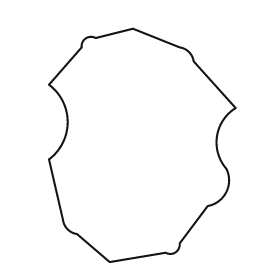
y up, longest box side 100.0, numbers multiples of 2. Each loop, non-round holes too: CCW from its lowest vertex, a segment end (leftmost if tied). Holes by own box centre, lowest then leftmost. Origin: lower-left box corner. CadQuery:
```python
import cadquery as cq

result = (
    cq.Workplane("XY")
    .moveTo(26.0, 0.0)
    .lineTo(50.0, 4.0)
    .threePointArc((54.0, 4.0), (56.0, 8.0))
    .lineTo(68.0, 24.0)
    .threePointArc((76.0, 30.0), (76.0, 40.0))
    .threePointArc((72.0, 54.0), (80.0, 66.0))
    .lineTo(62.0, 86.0)
    .threePointArc((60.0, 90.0), (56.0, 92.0))
    .lineTo(36.0, 100.0)
    .lineTo(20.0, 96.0)
    .threePointArc((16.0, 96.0), (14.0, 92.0))
    .lineTo(0.0, 76.0)
    .threePointArc((8.0, 60.0), (0.0, 44.0))
    .lineTo(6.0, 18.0)
    .threePointArc((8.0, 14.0), (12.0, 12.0))
    .close()
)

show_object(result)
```